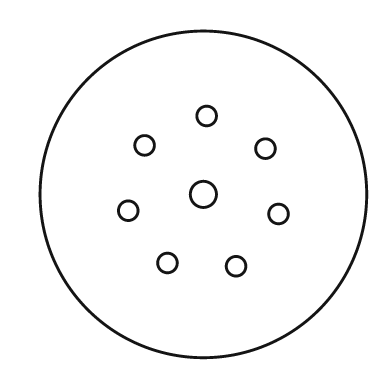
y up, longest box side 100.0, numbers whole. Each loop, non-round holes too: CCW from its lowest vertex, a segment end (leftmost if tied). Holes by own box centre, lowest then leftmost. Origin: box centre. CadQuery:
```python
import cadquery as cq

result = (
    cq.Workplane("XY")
    .moveTo(0.0, 0.0)
    .circle(50.0)
    .moveTo(10.0, -22.0)
    .circle(3.0)
    .moveTo(-11.0, -21.0)
    .circle(3.0)
    .moveTo(23.0, -6.0)
    .circle(3.0)
    .moveTo(-23.0, -5.0)
    .circle(3.0)
    .moveTo(0.0, 0.0)
    .circle(4.0)
    .moveTo(19.0, 14.0)
    .circle(3.0)
    .moveTo(-18.0, 15.0)
    .circle(3.0)
    .moveTo(1.0, 24.0)
    .circle(3.0)
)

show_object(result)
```